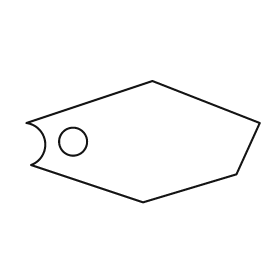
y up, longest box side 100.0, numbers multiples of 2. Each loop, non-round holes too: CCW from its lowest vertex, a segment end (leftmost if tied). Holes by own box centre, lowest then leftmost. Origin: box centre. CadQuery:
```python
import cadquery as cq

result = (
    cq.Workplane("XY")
    .moveTo(0.0, -26.0)
    .lineTo(40.0, -14.0)
    .lineTo(50.0, 8.0)
    .lineTo(4.0, 26.0)
    .lineTo(-50.0, 8.0)
    .threePointArc((-42.0, 0.0), (-48.0, -10.0))
    .close()
    .moveTo(-30.0, 0.0)
    .circle(6.0)
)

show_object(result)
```